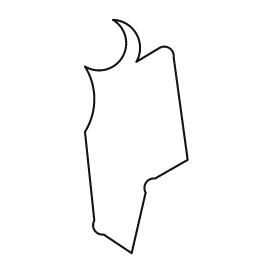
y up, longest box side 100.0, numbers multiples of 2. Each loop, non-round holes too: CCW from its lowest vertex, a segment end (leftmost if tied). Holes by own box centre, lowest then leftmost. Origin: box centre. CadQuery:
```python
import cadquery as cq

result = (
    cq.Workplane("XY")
    .moveTo(-2.0, -50.0)
    .lineTo(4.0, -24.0)
    .threePointArc((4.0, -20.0), (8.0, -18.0))
    .lineTo(22.0, -10.0)
    .lineTo(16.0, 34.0)
    .threePointArc((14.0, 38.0), (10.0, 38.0))
    .lineTo(0.0, 32.0)
    .threePointArc((0.0, 44.0), (-10.0, 50.0))
    .threePointArc((-6.0, 34.0), (-22.0, 30.0))
    .threePointArc((-18.0, 16.0), (-22.0, 2.0))
    .lineTo(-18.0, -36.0)
    .threePointArc((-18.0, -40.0), (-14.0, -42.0))
    .close()
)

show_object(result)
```